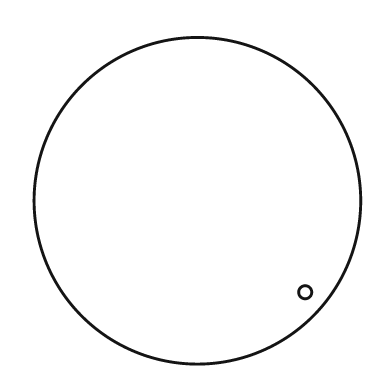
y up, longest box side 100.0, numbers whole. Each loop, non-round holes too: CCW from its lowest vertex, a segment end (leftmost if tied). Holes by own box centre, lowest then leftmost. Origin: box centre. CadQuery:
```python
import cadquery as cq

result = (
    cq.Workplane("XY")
    .moveTo(0.0, 0.0)
    .circle(50.0)
    .moveTo(33.0, -28.0)
    .circle(2.0)
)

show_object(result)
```